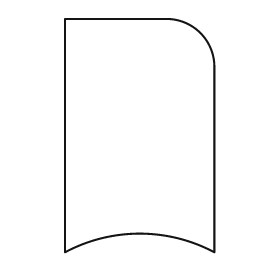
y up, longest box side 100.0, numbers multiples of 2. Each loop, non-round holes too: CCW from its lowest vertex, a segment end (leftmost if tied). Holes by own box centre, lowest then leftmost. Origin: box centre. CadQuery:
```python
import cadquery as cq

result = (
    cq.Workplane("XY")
    .moveTo(-32.0, -50.0)
    .threePointArc((0.0, -42.0), (32.0, -50.0))
    .lineTo(32.0, 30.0)
    .threePointArc((26.0, 44.0), (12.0, 50.0))
    .lineTo(-32.0, 50.0)
    .close()
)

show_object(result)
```